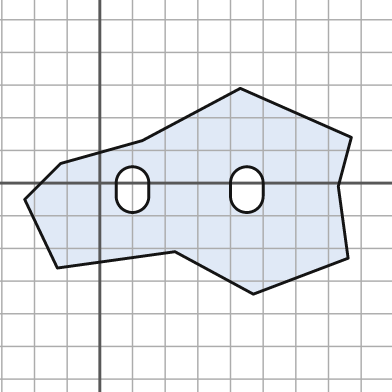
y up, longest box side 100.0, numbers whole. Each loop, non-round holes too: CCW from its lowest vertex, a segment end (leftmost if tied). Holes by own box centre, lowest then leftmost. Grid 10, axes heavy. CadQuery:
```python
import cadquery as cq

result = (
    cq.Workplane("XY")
    .moveTo(47.0, -34.0)
    .lineTo(76.0, -23.0)
    .lineTo(73.0, -1.0)
    .lineTo(77.0, 14.0)
    .lineTo(43.0, 29.0)
    .lineTo(13.0, 13.0)
    .lineTo(-12.0, 6.0)
    .lineTo(-23.0, -5.0)
    .lineTo(-13.0, -26.0)
    .lineTo(23.0, -21.0)
    .close()
    .moveTo(5.0, -4.0)
    .threePointArc((10.0, -9.0), (15.0, -4.0))
    .lineTo(15.0, 0.0)
    .threePointArc((10.0, 5.0), (5.0, 0.0))
    .close()
    .moveTo(40.0, -4.0)
    .threePointArc((45.0, -9.0), (50.0, -4.0))
    .lineTo(50.0, 0.0)
    .threePointArc((45.0, 5.0), (40.0, 0.0))
    .close()
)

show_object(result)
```